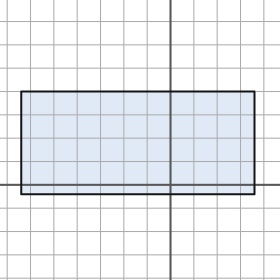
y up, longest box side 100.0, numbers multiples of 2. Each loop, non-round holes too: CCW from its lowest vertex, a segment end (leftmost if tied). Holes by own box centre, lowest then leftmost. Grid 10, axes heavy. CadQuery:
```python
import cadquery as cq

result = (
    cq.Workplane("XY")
    .moveTo(-64.0, -4.0)
    .lineTo(36.0, -4.0)
    .lineTo(36.0, 40.0)
    .lineTo(-64.0, 40.0)
    .close()
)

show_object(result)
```